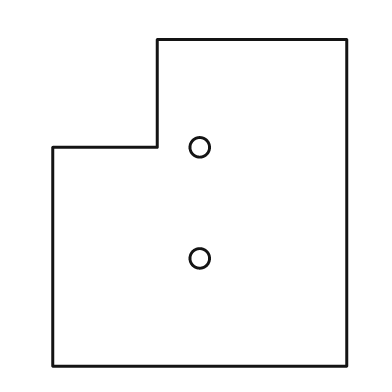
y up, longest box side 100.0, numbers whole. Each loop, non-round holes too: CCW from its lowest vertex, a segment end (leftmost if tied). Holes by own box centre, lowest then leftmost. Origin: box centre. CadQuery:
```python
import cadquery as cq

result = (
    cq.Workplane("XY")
    .moveTo(-45.0, -50.0)
    .lineTo(45.0, -50.0)
    .lineTo(45.0, 50.0)
    .lineTo(-13.0, 50.0)
    .lineTo(-13.0, 17.0)
    .lineTo(-45.0, 17.0)
    .close()
    .moveTo(0.0, -17.0)
    .circle(3.0)
    .moveTo(0.0, 17.0)
    .circle(3.0)
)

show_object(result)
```